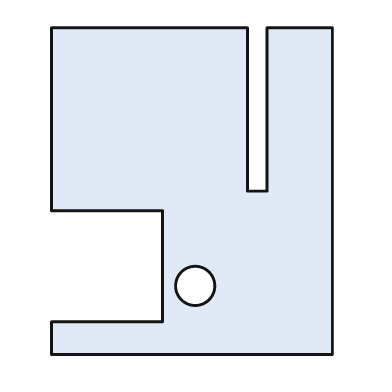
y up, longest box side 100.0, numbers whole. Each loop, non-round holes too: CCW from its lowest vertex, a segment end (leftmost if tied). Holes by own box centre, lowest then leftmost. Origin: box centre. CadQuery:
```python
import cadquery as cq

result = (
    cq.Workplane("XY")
    .moveTo(-43.0, -50.0)
    .lineTo(43.0, -50.0)
    .lineTo(43.0, 50.0)
    .lineTo(23.0, 50.0)
    .lineTo(23.0, 0.0)
    .lineTo(17.0, 0.0)
    .lineTo(17.0, 50.0)
    .lineTo(-43.0, 50.0)
    .lineTo(-43.0, -6.0)
    .lineTo(-9.0, -6.0)
    .lineTo(-9.0, -40.0)
    .lineTo(-43.0, -40.0)
    .close()
    .moveTo(1.0, -29.0)
    .circle(6.0)
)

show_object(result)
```